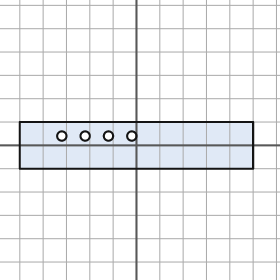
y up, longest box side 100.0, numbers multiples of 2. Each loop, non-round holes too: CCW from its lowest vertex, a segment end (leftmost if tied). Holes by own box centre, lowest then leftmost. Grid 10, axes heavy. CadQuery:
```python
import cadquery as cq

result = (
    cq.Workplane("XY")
    .moveTo(-50.0, -10.0)
    .lineTo(50.0, -10.0)
    .lineTo(50.0, 10.0)
    .lineTo(-50.0, 10.0)
    .close()
    .moveTo(-32.0, 4.0)
    .circle(2.0)
    .moveTo(-22.0, 4.0)
    .circle(2.0)
    .moveTo(-12.0, 4.0)
    .circle(2.0)
    .moveTo(-2.0, 4.0)
    .circle(2.0)
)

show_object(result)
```